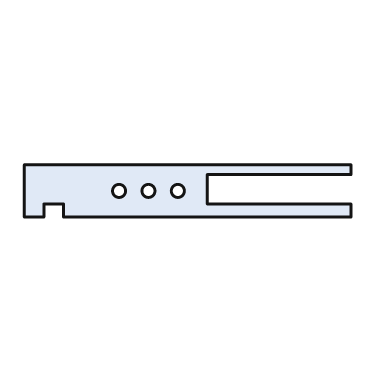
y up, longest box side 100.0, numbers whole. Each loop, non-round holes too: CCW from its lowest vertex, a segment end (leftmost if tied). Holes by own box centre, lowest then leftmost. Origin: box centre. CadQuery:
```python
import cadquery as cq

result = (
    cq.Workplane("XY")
    .moveTo(-50.0, -8.0)
    .lineTo(-44.0, -8.0)
    .lineTo(-44.0, -4.0)
    .lineTo(-38.0, -4.0)
    .lineTo(-38.0, -8.0)
    .lineTo(50.0, -8.0)
    .lineTo(50.0, -4.0)
    .lineTo(6.0, -4.0)
    .lineTo(6.0, 5.0)
    .lineTo(50.0, 5.0)
    .lineTo(50.0, 8.0)
    .lineTo(-50.0, 8.0)
    .close()
    .moveTo(-21.0, 0.0)
    .circle(2.0)
    .moveTo(-12.0, 0.0)
    .circle(2.0)
    .moveTo(-3.0, 0.0)
    .circle(2.0)
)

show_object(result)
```